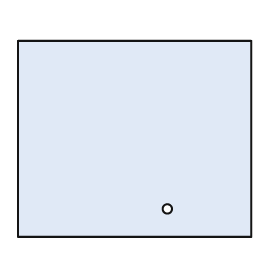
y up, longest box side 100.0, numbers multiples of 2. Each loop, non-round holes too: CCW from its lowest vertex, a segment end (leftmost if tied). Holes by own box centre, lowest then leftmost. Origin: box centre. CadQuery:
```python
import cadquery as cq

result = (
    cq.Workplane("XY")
    .moveTo(-50.0, -42.0)
    .lineTo(50.0, -42.0)
    .lineTo(50.0, 42.0)
    .lineTo(-50.0, 42.0)
    .close()
    .moveTo(14.0, -30.0)
    .circle(2.0)
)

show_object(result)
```